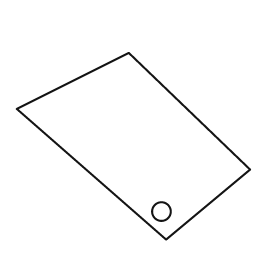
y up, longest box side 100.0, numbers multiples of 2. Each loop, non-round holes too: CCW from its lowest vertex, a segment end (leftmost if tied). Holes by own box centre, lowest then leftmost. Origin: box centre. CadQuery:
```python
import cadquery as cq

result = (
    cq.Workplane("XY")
    .moveTo(14.0, -40.0)
    .lineTo(50.0, -10.0)
    .lineTo(-2.0, 40.0)
    .lineTo(-50.0, 16.0)
    .close()
    .moveTo(12.0, -28.0)
    .circle(4.0)
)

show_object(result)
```